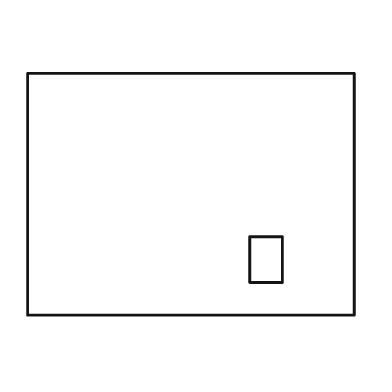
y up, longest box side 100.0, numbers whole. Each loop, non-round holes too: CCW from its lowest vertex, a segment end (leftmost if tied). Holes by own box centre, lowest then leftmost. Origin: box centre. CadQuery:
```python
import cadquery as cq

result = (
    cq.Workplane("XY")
    .moveTo(-50.0, -37.0)
    .lineTo(50.0, -37.0)
    .lineTo(50.0, 37.0)
    .lineTo(-50.0, 37.0)
    .close()
    .moveTo(18.0, -27.0)
    .lineTo(28.0, -27.0)
    .lineTo(28.0, -13.0)
    .lineTo(18.0, -13.0)
    .close()
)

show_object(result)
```